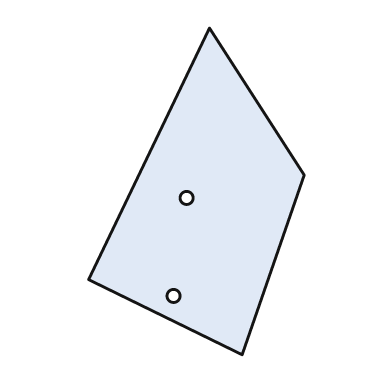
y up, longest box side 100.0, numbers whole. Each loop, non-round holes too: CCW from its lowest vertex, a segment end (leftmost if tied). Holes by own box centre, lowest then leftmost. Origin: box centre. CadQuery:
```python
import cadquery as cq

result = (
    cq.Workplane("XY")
    .moveTo(14.0, -50.0)
    .lineTo(33.0, 5.0)
    .lineTo(4.0, 50.0)
    .lineTo(-33.0, -27.0)
    .close()
    .moveTo(-7.0, -32.0)
    .circle(2.0)
    .moveTo(-3.0, -2.0)
    .circle(2.0)
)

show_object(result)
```